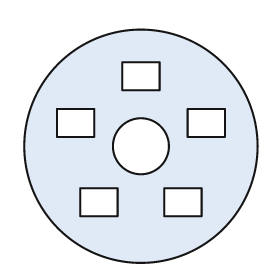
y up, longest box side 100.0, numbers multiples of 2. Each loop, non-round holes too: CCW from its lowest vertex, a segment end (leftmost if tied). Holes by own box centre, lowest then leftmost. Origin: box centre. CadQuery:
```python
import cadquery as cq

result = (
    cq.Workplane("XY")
    .moveTo(0.0, 0.0)
    .circle(50.0)
    .moveTo(-26.0, -30.0)
    .lineTo(-10.0, -30.0)
    .lineTo(-10.0, -18.0)
    .lineTo(-26.0, -18.0)
    .close()
    .moveTo(10.0, -30.0)
    .lineTo(26.0, -30.0)
    .lineTo(26.0, -18.0)
    .lineTo(10.0, -18.0)
    .close()
    .moveTo(0.0, 0.0)
    .circle(12.0)
    .moveTo(-36.0, 4.0)
    .lineTo(-20.0, 4.0)
    .lineTo(-20.0, 16.0)
    .lineTo(-36.0, 16.0)
    .close()
    .moveTo(20.0, 4.0)
    .lineTo(36.0, 4.0)
    .lineTo(36.0, 16.0)
    .lineTo(20.0, 16.0)
    .close()
    .moveTo(-8.0, 24.0)
    .lineTo(8.0, 24.0)
    .lineTo(8.0, 36.0)
    .lineTo(-8.0, 36.0)
    .close()
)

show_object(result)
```